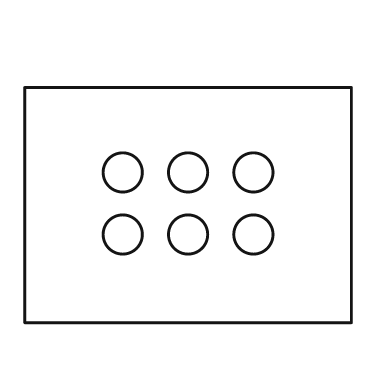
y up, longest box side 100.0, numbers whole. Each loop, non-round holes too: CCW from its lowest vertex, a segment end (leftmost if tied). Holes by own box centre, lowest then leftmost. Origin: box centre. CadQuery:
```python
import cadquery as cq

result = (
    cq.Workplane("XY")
    .moveTo(-50.0, -36.0)
    .lineTo(50.0, -36.0)
    .lineTo(50.0, 36.0)
    .lineTo(-50.0, 36.0)
    .close()
    .moveTo(-20.0, -9.0)
    .circle(6.0)
    .moveTo(0.0, -9.0)
    .circle(6.0)
    .moveTo(20.0, -9.0)
    .circle(6.0)
    .moveTo(-20.0, 10.0)
    .circle(6.0)
    .moveTo(0.0, 10.0)
    .circle(6.0)
    .moveTo(20.0, 10.0)
    .circle(6.0)
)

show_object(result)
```